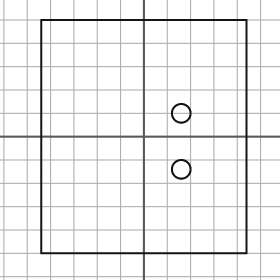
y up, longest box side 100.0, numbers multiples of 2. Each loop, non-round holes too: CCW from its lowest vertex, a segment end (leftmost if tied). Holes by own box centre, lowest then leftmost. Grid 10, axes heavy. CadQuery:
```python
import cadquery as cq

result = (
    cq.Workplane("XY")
    .moveTo(-44.0, -50.0)
    .lineTo(44.0, -50.0)
    .lineTo(44.0, 50.0)
    .lineTo(-44.0, 50.0)
    .close()
    .moveTo(16.0, -14.0)
    .circle(4.0)
    .moveTo(16.0, 10.0)
    .circle(4.0)
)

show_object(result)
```